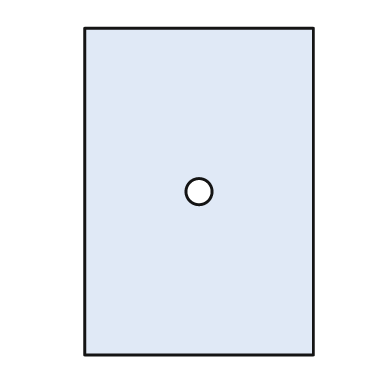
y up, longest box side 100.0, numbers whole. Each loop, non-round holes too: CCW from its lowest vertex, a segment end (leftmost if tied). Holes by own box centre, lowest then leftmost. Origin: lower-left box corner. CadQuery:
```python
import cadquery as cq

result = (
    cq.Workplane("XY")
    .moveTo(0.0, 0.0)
    .lineTo(70.0, 0.0)
    .lineTo(70.0, 100.0)
    .lineTo(0.0, 100.0)
    .close()
    .moveTo(35.0, 50.0)
    .circle(4.0)
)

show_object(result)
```